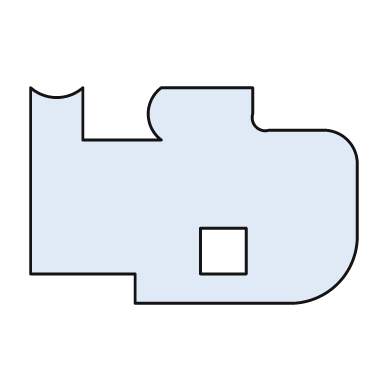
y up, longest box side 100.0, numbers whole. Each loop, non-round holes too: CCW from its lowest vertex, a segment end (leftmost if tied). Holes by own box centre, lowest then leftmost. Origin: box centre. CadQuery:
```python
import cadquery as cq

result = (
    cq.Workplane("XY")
    .moveTo(-18.0, -33.0)
    .lineTo(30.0, -33.0)
    .threePointArc((44.0, -27.0), (50.0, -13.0))
    .lineTo(50.0, 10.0)
    .threePointArc((47.0, 17.0), (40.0, 20.0))
    .lineTo(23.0, 20.0)
    .threePointArc((19.0, 21.0), (18.0, 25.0))
    .lineTo(18.0, 33.0)
    .lineTo(-10.0, 33.0)
    .threePointArc((-14.0, 25.0), (-10.0, 17.0))
    .lineTo(-34.0, 17.0)
    .lineTo(-34.0, 33.0)
    .threePointArc((-42.0, 30.0), (-50.0, 33.0))
    .lineTo(-50.0, -24.0)
    .lineTo(-18.0, -24.0)
    .close()
    .moveTo(2.0, -24.0)
    .lineTo(16.0, -24.0)
    .lineTo(16.0, -10.0)
    .lineTo(2.0, -10.0)
    .close()
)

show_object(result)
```